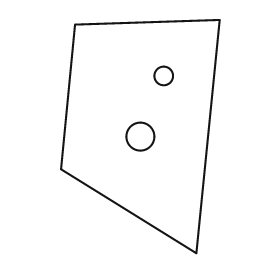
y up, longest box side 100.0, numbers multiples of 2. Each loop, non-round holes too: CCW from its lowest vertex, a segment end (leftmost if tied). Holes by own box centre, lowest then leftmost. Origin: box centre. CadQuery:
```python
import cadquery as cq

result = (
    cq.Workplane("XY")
    .moveTo(24.0, -50.0)
    .lineTo(34.0, 50.0)
    .lineTo(-28.0, 48.0)
    .lineTo(-34.0, -14.0)
    .close()
    .moveTo(0.0, 0.0)
    .circle(6.0)
    .moveTo(10.0, 26.0)
    .circle(4.0)
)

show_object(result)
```